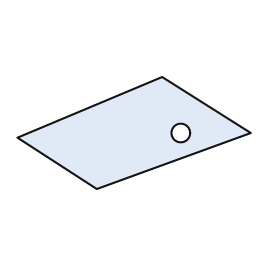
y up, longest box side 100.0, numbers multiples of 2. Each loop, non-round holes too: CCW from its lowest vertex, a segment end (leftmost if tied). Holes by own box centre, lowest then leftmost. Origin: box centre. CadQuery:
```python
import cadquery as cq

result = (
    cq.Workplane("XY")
    .moveTo(-16.0, -24.0)
    .lineTo(50.0, 0.0)
    .lineTo(12.0, 24.0)
    .lineTo(-50.0, -2.0)
    .close()
    .moveTo(20.0, 0.0)
    .circle(4.0)
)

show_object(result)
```